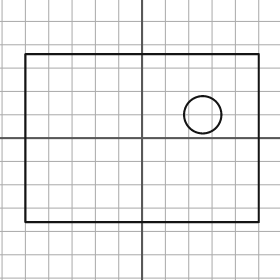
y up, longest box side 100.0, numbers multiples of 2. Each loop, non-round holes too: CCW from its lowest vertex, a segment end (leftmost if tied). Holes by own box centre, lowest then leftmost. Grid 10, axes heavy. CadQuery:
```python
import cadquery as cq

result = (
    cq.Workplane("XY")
    .moveTo(-50.0, -36.0)
    .lineTo(50.0, -36.0)
    .lineTo(50.0, 36.0)
    .lineTo(-50.0, 36.0)
    .close()
    .moveTo(26.0, 10.0)
    .circle(8.0)
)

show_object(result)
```